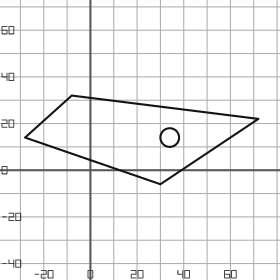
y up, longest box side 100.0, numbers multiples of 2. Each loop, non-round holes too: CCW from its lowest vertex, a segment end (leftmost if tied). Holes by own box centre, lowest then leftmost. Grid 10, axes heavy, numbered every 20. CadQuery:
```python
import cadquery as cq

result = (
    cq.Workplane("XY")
    .moveTo(30.0, -6.0)
    .lineTo(72.0, 22.0)
    .lineTo(-8.0, 32.0)
    .lineTo(-28.0, 14.0)
    .close()
    .moveTo(34.0, 14.0)
    .circle(4.0)
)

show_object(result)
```